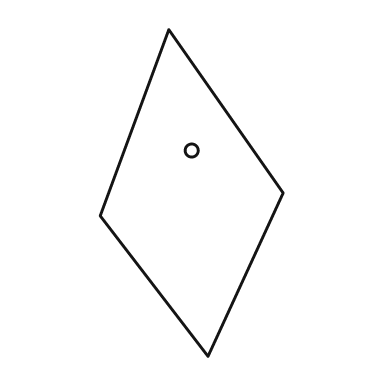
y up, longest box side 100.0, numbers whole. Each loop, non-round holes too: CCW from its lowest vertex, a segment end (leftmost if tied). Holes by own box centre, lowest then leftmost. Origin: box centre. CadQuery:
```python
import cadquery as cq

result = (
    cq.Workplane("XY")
    .moveTo(5.0, -50.0)
    .lineTo(28.0, 0.0)
    .lineTo(-7.0, 50.0)
    .lineTo(-28.0, -7.0)
    .close()
    .moveTo(0.0, 13.0)
    .circle(2.0)
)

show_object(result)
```